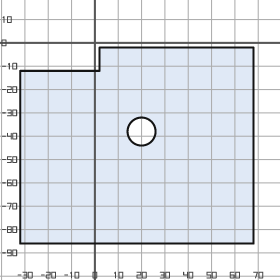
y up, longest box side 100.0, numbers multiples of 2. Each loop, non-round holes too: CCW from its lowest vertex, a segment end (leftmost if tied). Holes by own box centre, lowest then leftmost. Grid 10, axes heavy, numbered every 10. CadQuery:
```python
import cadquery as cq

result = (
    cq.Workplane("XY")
    .moveTo(-32.0, -86.0)
    .lineTo(68.0, -86.0)
    .lineTo(68.0, -2.0)
    .lineTo(2.0, -2.0)
    .lineTo(2.0, -12.0)
    .lineTo(-32.0, -12.0)
    .close()
    .moveTo(20.0, -38.0)
    .circle(6.0)
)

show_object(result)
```